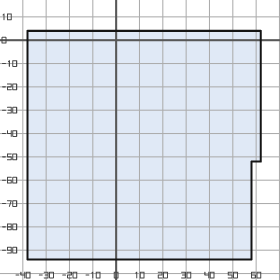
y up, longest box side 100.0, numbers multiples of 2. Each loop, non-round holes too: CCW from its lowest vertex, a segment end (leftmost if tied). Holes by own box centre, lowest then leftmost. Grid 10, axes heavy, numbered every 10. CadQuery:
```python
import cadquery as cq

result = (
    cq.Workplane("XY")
    .moveTo(-38.0, -94.0)
    .lineTo(58.0, -94.0)
    .lineTo(58.0, -52.0)
    .lineTo(62.0, -52.0)
    .lineTo(62.0, 4.0)
    .lineTo(-38.0, 4.0)
    .close()
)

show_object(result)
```